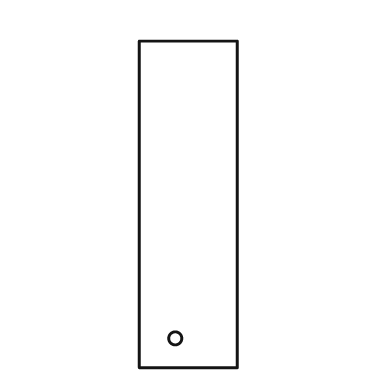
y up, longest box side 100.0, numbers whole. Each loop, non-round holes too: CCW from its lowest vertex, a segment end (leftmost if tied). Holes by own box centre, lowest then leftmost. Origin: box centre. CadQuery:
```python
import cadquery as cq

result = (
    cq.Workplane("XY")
    .moveTo(-15.0, -50.0)
    .lineTo(15.0, -50.0)
    .lineTo(15.0, 50.0)
    .lineTo(-15.0, 50.0)
    .close()
    .moveTo(-4.0, -41.0)
    .circle(2.0)
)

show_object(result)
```